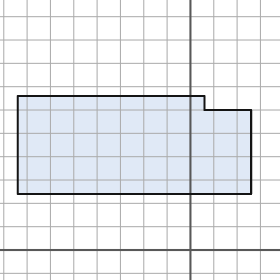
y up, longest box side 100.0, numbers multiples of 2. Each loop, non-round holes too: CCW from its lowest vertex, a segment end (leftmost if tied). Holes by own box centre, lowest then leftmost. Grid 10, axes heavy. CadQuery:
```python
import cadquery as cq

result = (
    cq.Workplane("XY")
    .moveTo(-74.0, 24.0)
    .lineTo(26.0, 24.0)
    .lineTo(26.0, 60.0)
    .lineTo(6.0, 60.0)
    .lineTo(6.0, 66.0)
    .lineTo(-74.0, 66.0)
    .close()
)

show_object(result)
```